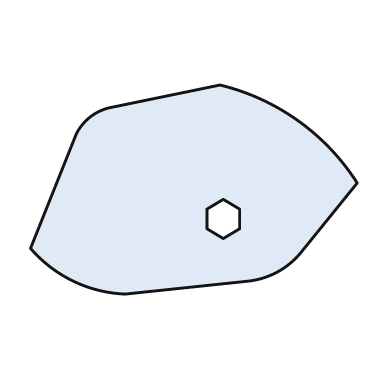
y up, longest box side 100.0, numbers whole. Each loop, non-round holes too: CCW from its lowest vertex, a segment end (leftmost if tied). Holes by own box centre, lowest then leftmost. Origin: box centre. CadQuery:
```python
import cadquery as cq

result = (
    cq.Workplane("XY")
    .moveTo(-21.0, -32.0)
    .lineTo(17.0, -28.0)
    .threePointArc((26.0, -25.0), (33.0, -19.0))
    .lineTo(50.0, 2.0)
    .threePointArc((32.0, 21.0), (8.0, 32.0))
    .lineTo(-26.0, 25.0)
    .threePointArc((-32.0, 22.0), (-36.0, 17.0))
    .lineTo(-50.0, -18.0)
    .threePointArc((-37.0, -28.0), (-21.0, -32.0))
    .close()
    .moveTo(9.0, -15.0)
    .lineTo(14.0, -12.0)
    .lineTo(14.0, -6.0)
    .lineTo(9.0, -3.0)
    .lineTo(4.0, -6.0)
    .lineTo(4.0, -12.0)
    .close()
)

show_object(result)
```